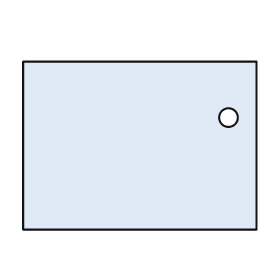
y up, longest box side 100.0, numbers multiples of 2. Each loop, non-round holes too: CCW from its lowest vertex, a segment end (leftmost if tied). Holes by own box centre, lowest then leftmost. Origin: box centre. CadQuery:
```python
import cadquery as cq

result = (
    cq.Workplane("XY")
    .moveTo(-50.0, -36.0)
    .lineTo(50.0, -36.0)
    .lineTo(50.0, 36.0)
    .lineTo(-50.0, 36.0)
    .close()
    .moveTo(38.0, 12.0)
    .circle(4.0)
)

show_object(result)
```